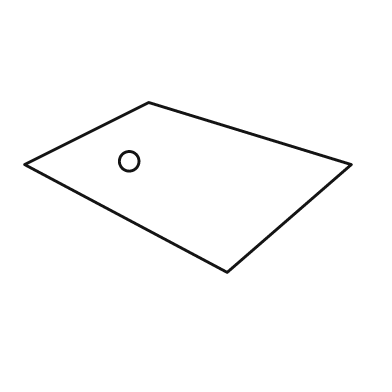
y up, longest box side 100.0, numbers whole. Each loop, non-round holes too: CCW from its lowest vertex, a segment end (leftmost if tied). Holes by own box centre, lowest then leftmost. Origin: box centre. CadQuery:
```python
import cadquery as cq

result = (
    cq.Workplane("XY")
    .moveTo(12.0, -26.0)
    .lineTo(50.0, 7.0)
    .lineTo(-12.0, 26.0)
    .lineTo(-50.0, 7.0)
    .close()
    .moveTo(-18.0, 8.0)
    .circle(3.0)
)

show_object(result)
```